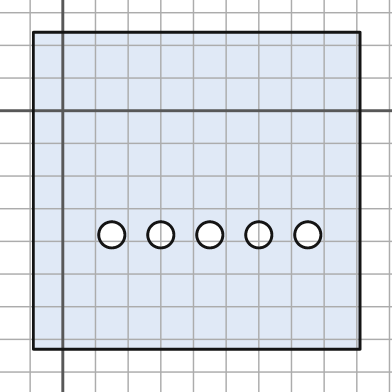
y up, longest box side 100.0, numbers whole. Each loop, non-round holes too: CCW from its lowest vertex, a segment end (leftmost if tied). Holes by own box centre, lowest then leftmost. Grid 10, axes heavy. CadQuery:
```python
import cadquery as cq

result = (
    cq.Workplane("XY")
    .moveTo(-9.0, -73.0)
    .lineTo(91.0, -73.0)
    .lineTo(91.0, 24.0)
    .lineTo(-9.0, 24.0)
    .close()
    .moveTo(15.0, -38.0)
    .circle(4.0)
    .moveTo(30.0, -38.0)
    .circle(4.0)
    .moveTo(45.0, -38.0)
    .circle(4.0)
    .moveTo(60.0, -38.0)
    .circle(4.0)
    .moveTo(75.0, -38.0)
    .circle(4.0)
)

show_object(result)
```